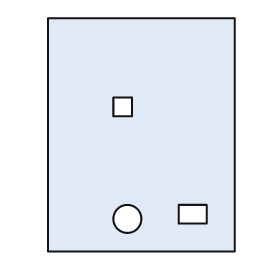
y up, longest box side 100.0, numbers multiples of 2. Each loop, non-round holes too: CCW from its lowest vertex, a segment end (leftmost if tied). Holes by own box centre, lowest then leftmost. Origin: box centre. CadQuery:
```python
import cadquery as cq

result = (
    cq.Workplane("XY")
    .moveTo(-40.0, -50.0)
    .lineTo(40.0, -50.0)
    .lineTo(40.0, 50.0)
    .lineTo(-40.0, 50.0)
    .close()
    .moveTo(-6.0, -36.0)
    .circle(6.0)
    .moveTo(16.0, -38.0)
    .lineTo(28.0, -38.0)
    .lineTo(28.0, -30.0)
    .lineTo(16.0, -30.0)
    .close()
    .moveTo(-12.0, 8.0)
    .lineTo(-4.0, 8.0)
    .lineTo(-4.0, 16.0)
    .lineTo(-12.0, 16.0)
    .close()
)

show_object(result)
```